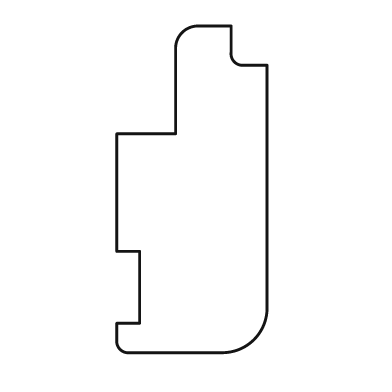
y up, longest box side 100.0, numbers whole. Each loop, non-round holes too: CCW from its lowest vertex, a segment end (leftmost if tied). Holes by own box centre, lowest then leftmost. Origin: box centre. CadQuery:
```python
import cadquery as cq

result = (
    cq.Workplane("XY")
    .moveTo(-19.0, -50.0)
    .lineTo(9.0, -50.0)
    .threePointArc((19.0, -46.0), (23.0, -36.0))
    .lineTo(23.0, 38.0)
    .lineTo(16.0, 38.0)
    .threePointArc((13.0, 39.0), (12.0, 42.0))
    .lineTo(12.0, 50.0)
    .lineTo(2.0, 50.0)
    .threePointArc((-3.0, 48.0), (-5.0, 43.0))
    .lineTo(-5.0, 17.0)
    .lineTo(-23.0, 17.0)
    .lineTo(-23.0, -19.0)
    .lineTo(-16.0, -19.0)
    .lineTo(-16.0, -41.0)
    .lineTo(-23.0, -41.0)
    .lineTo(-23.0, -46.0)
    .threePointArc((-22.0, -49.0), (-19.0, -50.0))
    .close()
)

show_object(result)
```